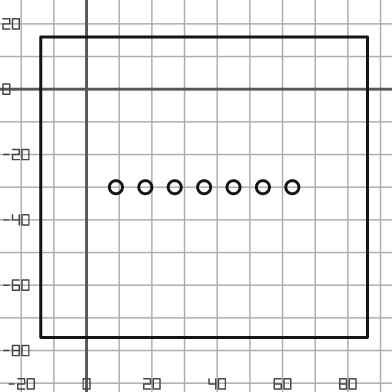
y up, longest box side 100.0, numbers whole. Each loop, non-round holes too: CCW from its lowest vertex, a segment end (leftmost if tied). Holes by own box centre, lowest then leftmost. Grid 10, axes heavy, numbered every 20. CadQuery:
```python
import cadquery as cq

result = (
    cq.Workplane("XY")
    .moveTo(-14.0, -76.0)
    .lineTo(86.0, -76.0)
    .lineTo(86.0, 16.0)
    .lineTo(-14.0, 16.0)
    .close()
    .moveTo(9.0, -30.0)
    .circle(2.0)
    .moveTo(18.0, -30.0)
    .circle(2.0)
    .moveTo(27.0, -30.0)
    .circle(2.0)
    .moveTo(36.0, -30.0)
    .circle(2.0)
    .moveTo(45.0, -30.0)
    .circle(2.0)
    .moveTo(54.0, -30.0)
    .circle(2.0)
    .moveTo(63.0, -30.0)
    .circle(2.0)
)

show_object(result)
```